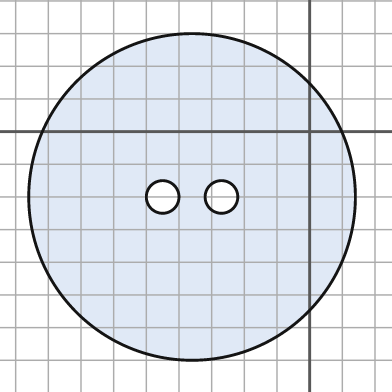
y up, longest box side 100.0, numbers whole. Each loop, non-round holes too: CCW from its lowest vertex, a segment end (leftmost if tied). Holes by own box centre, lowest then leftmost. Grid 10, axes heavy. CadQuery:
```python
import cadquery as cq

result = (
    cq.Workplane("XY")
    .moveTo(-36.0, -20.0)
    .circle(50.0)
    .moveTo(-45.0, -20.0)
    .circle(5.0)
    .moveTo(-27.0, -20.0)
    .circle(5.0)
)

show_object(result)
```